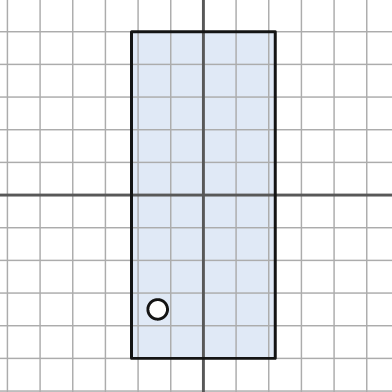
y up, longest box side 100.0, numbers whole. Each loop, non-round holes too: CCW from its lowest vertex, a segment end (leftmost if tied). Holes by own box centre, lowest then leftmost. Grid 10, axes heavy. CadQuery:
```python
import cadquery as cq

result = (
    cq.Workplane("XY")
    .moveTo(-22.0, -50.0)
    .lineTo(22.0, -50.0)
    .lineTo(22.0, 50.0)
    .lineTo(-22.0, 50.0)
    .close()
    .moveTo(-14.0, -35.0)
    .circle(3.0)
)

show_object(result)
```